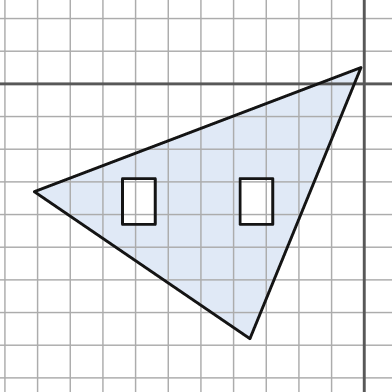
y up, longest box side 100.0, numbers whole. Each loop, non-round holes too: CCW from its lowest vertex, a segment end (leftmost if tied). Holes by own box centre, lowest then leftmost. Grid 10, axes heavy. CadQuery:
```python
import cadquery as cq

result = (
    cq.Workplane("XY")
    .moveTo(-35.0, -78.0)
    .lineTo(-1.0, 5.0)
    .lineTo(-101.0, -33.0)
    .close()
    .moveTo(-74.0, -43.0)
    .lineTo(-64.0, -43.0)
    .lineTo(-64.0, -29.0)
    .lineTo(-74.0, -29.0)
    .close()
    .moveTo(-38.0, -43.0)
    .lineTo(-28.0, -43.0)
    .lineTo(-28.0, -29.0)
    .lineTo(-38.0, -29.0)
    .close()
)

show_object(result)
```